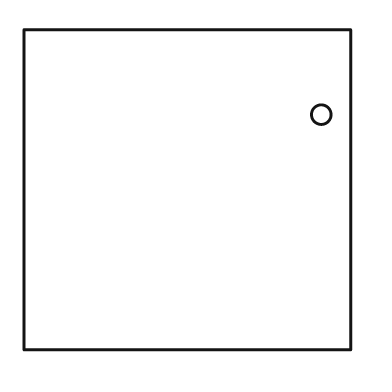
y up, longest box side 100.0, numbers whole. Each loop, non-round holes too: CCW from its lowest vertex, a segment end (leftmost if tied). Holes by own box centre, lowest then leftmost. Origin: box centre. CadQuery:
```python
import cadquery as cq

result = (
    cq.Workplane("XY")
    .moveTo(-50.0, -49.0)
    .lineTo(50.0, -49.0)
    .lineTo(50.0, 49.0)
    .lineTo(-50.0, 49.0)
    .close()
    .moveTo(41.0, 23.0)
    .circle(3.0)
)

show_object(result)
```